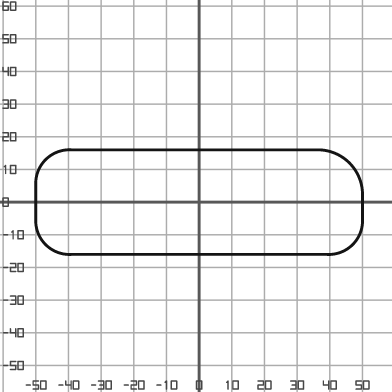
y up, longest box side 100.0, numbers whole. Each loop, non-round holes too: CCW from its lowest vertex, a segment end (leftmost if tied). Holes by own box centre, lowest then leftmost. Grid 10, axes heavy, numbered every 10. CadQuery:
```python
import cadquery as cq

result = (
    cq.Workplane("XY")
    .moveTo(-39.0, -16.0)
    .lineTo(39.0, -16.0)
    .threePointArc((47.0, -13.0), (50.0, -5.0))
    .lineTo(50.0, 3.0)
    .threePointArc((46.0, 12.0), (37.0, 16.0))
    .lineTo(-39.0, 16.0)
    .threePointArc((-47.0, 13.0), (-50.0, 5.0))
    .lineTo(-50.0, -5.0)
    .threePointArc((-47.0, -13.0), (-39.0, -16.0))
    .close()
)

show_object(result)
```